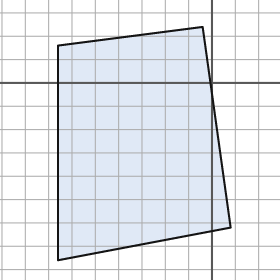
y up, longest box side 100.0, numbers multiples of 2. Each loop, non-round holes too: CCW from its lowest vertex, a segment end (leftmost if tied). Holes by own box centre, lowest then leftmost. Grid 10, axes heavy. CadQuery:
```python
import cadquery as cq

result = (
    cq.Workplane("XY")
    .moveTo(-66.0, -76.0)
    .lineTo(8.0, -62.0)
    .lineTo(-4.0, 24.0)
    .lineTo(-66.0, 16.0)
    .close()
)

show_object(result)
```